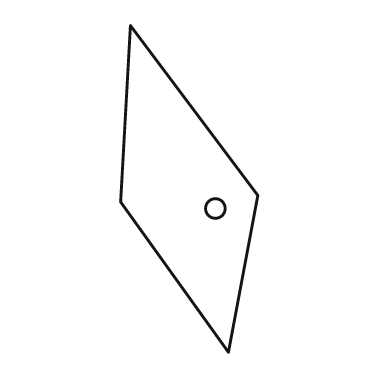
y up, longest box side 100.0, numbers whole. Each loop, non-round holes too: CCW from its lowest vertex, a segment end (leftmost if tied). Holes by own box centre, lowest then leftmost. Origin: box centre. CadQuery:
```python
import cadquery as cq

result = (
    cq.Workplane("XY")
    .moveTo(12.0, -50.0)
    .lineTo(21.0, -2.0)
    .lineTo(-18.0, 50.0)
    .lineTo(-21.0, -4.0)
    .close()
    .moveTo(8.0, -6.0)
    .circle(3.0)
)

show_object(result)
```